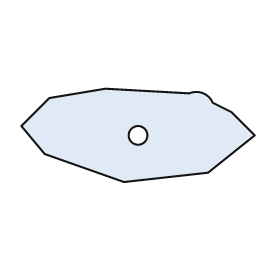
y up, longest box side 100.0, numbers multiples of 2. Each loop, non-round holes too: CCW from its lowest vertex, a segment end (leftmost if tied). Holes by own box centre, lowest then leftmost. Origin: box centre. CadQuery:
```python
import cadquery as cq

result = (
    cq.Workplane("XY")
    .moveTo(-6.0, -20.0)
    .lineTo(30.0, -16.0)
    .lineTo(50.0, 0.0)
    .lineTo(40.0, 10.0)
    .lineTo(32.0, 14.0)
    .threePointArc((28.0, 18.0), (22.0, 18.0))
    .lineTo(-14.0, 20.0)
    .lineTo(-38.0, 16.0)
    .lineTo(-50.0, 4.0)
    .lineTo(-40.0, -8.0)
    .close()
    .moveTo(0.0, 0.0)
    .circle(4.0)
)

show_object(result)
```